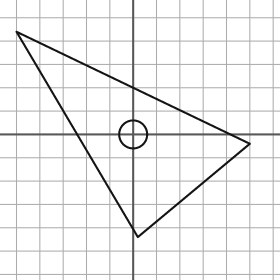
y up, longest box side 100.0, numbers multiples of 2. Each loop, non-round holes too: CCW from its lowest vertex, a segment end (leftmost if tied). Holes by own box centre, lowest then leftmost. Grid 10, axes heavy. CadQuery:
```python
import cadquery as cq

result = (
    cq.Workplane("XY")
    .moveTo(2.0, -44.0)
    .lineTo(50.0, -4.0)
    .lineTo(-50.0, 44.0)
    .close()
    .moveTo(0.0, 0.0)
    .circle(6.0)
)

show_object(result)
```